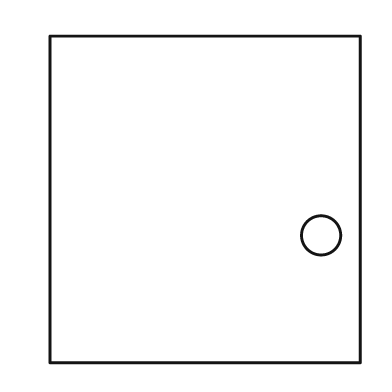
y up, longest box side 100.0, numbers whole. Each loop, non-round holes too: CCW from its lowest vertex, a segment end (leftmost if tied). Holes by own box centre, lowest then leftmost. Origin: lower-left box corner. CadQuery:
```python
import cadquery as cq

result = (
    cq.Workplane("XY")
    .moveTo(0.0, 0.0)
    .lineTo(95.0, 0.0)
    .lineTo(95.0, 100.0)
    .lineTo(0.0, 100.0)
    .close()
    .moveTo(83.0, 39.0)
    .circle(6.0)
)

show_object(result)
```